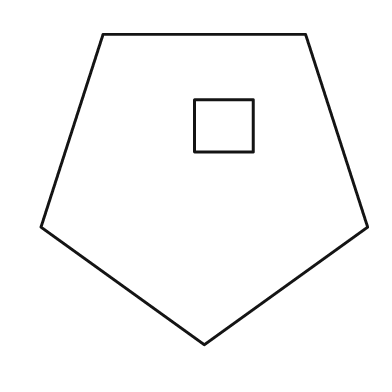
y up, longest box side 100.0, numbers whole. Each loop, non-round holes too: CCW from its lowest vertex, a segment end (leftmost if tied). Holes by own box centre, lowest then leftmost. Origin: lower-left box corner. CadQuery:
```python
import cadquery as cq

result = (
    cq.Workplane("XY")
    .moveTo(50.0, 0.0)
    .lineTo(100.0, 36.0)
    .lineTo(81.0, 95.0)
    .lineTo(19.0, 95.0)
    .lineTo(0.0, 36.0)
    .close()
    .moveTo(47.0, 59.0)
    .lineTo(65.0, 59.0)
    .lineTo(65.0, 75.0)
    .lineTo(47.0, 75.0)
    .close()
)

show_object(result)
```